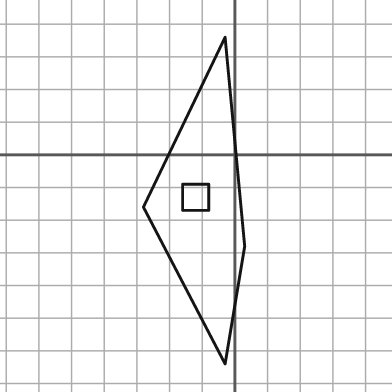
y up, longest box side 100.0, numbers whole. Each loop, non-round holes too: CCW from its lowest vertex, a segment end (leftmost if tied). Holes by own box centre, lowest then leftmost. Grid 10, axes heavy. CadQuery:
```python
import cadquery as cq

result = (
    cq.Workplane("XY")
    .moveTo(-3.0, -64.0)
    .lineTo(3.0, -28.0)
    .lineTo(-3.0, 36.0)
    .lineTo(-28.0, -16.0)
    .close()
    .moveTo(-16.0, -17.0)
    .lineTo(-8.0, -17.0)
    .lineTo(-8.0, -9.0)
    .lineTo(-16.0, -9.0)
    .close()
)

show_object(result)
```